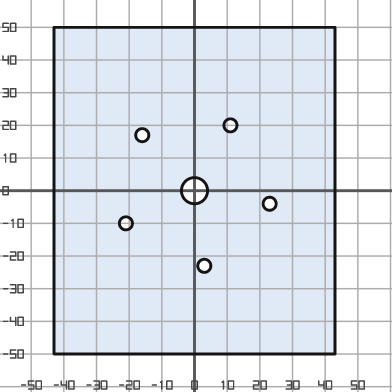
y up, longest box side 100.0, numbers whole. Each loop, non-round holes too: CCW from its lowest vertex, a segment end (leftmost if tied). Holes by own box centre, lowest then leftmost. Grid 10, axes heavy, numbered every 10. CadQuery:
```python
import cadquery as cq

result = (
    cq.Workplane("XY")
    .moveTo(-43.0, -50.0)
    .lineTo(43.0, -50.0)
    .lineTo(43.0, 50.0)
    .lineTo(-43.0, 50.0)
    .close()
    .moveTo(3.0, -23.0)
    .circle(2.0)
    .moveTo(-21.0, -10.0)
    .circle(2.0)
    .moveTo(23.0, -4.0)
    .circle(2.0)
    .moveTo(0.0, 0.0)
    .circle(4.0)
    .moveTo(-16.0, 17.0)
    .circle(2.0)
    .moveTo(11.0, 20.0)
    .circle(2.0)
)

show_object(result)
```